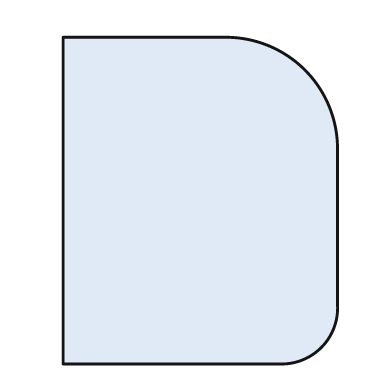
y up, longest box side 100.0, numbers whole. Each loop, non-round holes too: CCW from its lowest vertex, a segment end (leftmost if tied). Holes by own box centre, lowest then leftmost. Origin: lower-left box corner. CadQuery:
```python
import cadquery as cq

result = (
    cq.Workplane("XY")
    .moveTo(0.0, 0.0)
    .lineTo(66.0, 0.0)
    .threePointArc((79.0, 5.0), (84.0, 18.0))
    .lineTo(84.0, 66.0)
    .threePointArc((74.0, 90.0), (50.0, 100.0))
    .lineTo(0.0, 100.0)
    .close()
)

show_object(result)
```